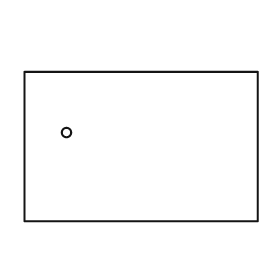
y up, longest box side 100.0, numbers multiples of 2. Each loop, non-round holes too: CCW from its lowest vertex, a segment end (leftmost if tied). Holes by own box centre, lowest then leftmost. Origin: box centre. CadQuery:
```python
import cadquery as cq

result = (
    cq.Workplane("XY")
    .moveTo(-50.0, -32.0)
    .lineTo(50.0, -32.0)
    .lineTo(50.0, 32.0)
    .lineTo(-50.0, 32.0)
    .close()
    .moveTo(-32.0, 6.0)
    .circle(2.0)
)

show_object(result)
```